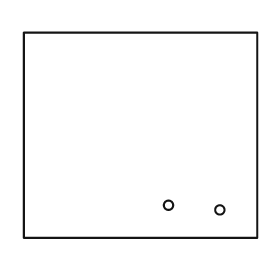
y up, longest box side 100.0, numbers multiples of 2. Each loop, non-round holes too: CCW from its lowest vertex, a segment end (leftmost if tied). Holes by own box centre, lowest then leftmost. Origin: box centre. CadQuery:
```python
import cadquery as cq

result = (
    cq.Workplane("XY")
    .moveTo(-50.0, -44.0)
    .lineTo(50.0, -44.0)
    .lineTo(50.0, 44.0)
    .lineTo(-50.0, 44.0)
    .close()
    .moveTo(34.0, -32.0)
    .circle(2.0)
    .moveTo(12.0, -30.0)
    .circle(2.0)
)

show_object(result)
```